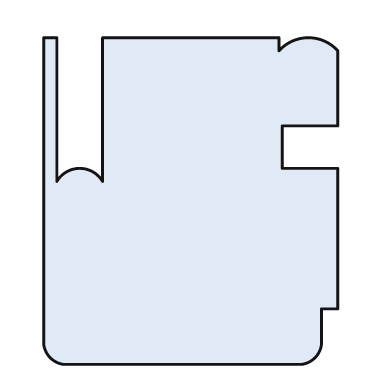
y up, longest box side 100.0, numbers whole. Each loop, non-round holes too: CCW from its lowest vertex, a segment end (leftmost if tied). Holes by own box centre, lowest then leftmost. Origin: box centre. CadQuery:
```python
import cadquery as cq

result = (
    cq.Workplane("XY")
    .moveTo(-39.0, -50.0)
    .lineTo(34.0, -50.0)
    .threePointArc((38.0, -48.0), (40.0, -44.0))
    .lineTo(40.0, -33.0)
    .lineTo(45.0, -33.0)
    .lineTo(45.0, 10.0)
    .lineTo(28.0, 10.0)
    .lineTo(28.0, 23.0)
    .lineTo(45.0, 23.0)
    .lineTo(45.0, 46.0)
    .threePointArc((36.0, 50.0), (27.0, 46.0))
    .lineTo(27.0, 50.0)
    .lineTo(-27.0, 50.0)
    .lineTo(-27.0, 6.0)
    .threePointArc((-34.0, 10.0), (-41.0, 6.0))
    .lineTo(-41.0, 50.0)
    .lineTo(-45.0, 50.0)
    .lineTo(-45.0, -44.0)
    .threePointArc((-43.0, -48.0), (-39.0, -50.0))
    .close()
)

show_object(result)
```